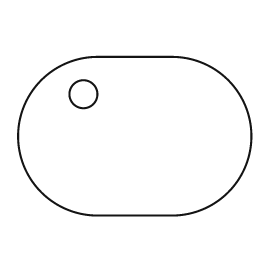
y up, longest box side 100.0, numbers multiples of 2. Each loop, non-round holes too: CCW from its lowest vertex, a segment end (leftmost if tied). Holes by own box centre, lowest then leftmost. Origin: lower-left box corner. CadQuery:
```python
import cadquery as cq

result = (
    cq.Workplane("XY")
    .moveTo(34.0, 0.0)
    .lineTo(66.0, 0.0)
    .threePointArc((100.0, 34.0), (66.0, 68.0))
    .lineTo(34.0, 68.0)
    .threePointArc((0.0, 34.0), (34.0, 0.0))
    .close()
    .moveTo(28.0, 52.0)
    .circle(6.0)
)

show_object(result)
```